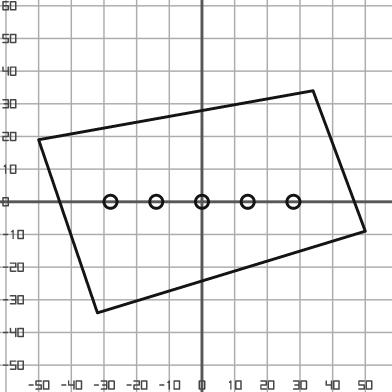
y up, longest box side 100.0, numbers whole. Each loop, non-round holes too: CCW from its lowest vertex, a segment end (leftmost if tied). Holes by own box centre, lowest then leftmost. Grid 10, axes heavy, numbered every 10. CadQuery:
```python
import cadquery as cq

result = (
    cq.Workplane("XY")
    .moveTo(-32.0, -34.0)
    .lineTo(50.0, -9.0)
    .lineTo(34.0, 34.0)
    .lineTo(-50.0, 19.0)
    .close()
    .moveTo(-28.0, 0.0)
    .circle(2.0)
    .moveTo(-14.0, 0.0)
    .circle(2.0)
    .moveTo(0.0, 0.0)
    .circle(2.0)
    .moveTo(14.0, 0.0)
    .circle(2.0)
    .moveTo(28.0, 0.0)
    .circle(2.0)
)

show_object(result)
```